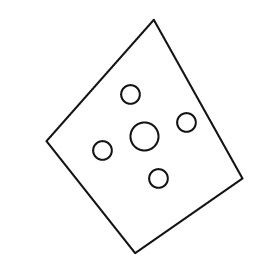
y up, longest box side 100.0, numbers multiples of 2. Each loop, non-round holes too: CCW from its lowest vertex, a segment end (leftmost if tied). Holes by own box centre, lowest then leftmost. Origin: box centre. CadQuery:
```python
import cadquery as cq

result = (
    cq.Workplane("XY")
    .moveTo(-4.0, -50.0)
    .lineTo(42.0, -18.0)
    .lineTo(4.0, 50.0)
    .lineTo(-42.0, -2.0)
    .close()
    .moveTo(6.0, -18.0)
    .circle(4.0)
    .moveTo(-18.0, -6.0)
    .circle(4.0)
    .moveTo(0.0, 0.0)
    .circle(6.0)
    .moveTo(18.0, 6.0)
    .circle(4.0)
    .moveTo(-6.0, 18.0)
    .circle(4.0)
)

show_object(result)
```